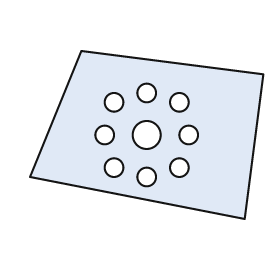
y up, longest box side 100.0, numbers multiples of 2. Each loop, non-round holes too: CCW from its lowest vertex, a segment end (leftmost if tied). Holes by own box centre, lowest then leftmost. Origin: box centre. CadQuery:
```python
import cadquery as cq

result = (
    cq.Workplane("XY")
    .moveTo(42.0, -36.0)
    .lineTo(50.0, 26.0)
    .lineTo(-28.0, 36.0)
    .lineTo(-50.0, -18.0)
    .close()
    .moveTo(0.0, -18.0)
    .circle(4.0)
    .moveTo(-14.0, -14.0)
    .circle(4.0)
    .moveTo(14.0, -14.0)
    .circle(4.0)
    .moveTo(-18.0, 0.0)
    .circle(4.0)
    .moveTo(0.0, 0.0)
    .circle(6.0)
    .moveTo(18.0, 0.0)
    .circle(4.0)
    .moveTo(-14.0, 14.0)
    .circle(4.0)
    .moveTo(14.0, 14.0)
    .circle(4.0)
    .moveTo(0.0, 18.0)
    .circle(4.0)
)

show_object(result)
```